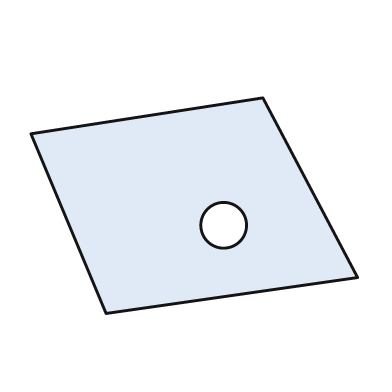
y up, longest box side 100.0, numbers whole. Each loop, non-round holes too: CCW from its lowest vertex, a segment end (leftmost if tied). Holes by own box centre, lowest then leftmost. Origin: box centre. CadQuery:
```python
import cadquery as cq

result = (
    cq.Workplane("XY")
    .moveTo(-27.0, -33.0)
    .lineTo(50.0, -22.0)
    .lineTo(21.0, 33.0)
    .lineTo(-50.0, 22.0)
    .close()
    .moveTo(9.0, -6.0)
    .circle(7.0)
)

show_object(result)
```